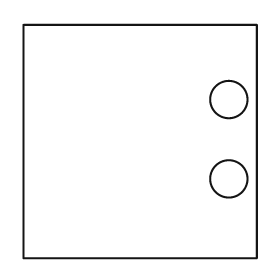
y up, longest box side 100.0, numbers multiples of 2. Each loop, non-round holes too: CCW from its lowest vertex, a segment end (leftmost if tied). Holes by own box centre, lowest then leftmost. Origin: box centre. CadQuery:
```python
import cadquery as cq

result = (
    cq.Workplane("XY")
    .moveTo(-50.0, -50.0)
    .lineTo(50.0, -50.0)
    .lineTo(50.0, 50.0)
    .lineTo(-50.0, 50.0)
    .close()
    .moveTo(38.0, -16.0)
    .circle(8.0)
    .moveTo(38.0, 18.0)
    .circle(8.0)
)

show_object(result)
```